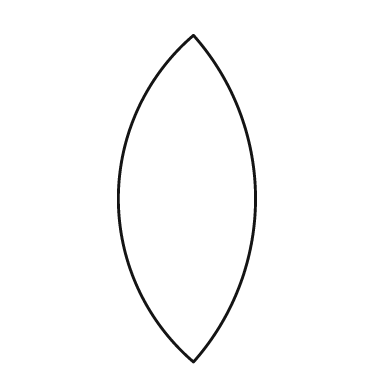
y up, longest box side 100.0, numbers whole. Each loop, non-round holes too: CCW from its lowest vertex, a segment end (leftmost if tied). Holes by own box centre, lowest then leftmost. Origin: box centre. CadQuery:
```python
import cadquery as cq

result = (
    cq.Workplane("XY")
    .moveTo(2.0, -50.0)
    .threePointArc((21.0, 0.0), (2.0, 50.0))
    .threePointArc((-21.0, 0.0), (2.0, -50.0))
    .close()
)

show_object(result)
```